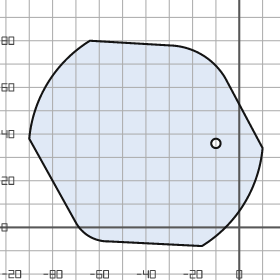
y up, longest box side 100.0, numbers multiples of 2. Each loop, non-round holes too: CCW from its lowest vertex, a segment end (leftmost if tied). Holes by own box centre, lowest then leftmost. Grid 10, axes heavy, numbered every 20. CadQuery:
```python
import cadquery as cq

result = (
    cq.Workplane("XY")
    .moveTo(-16.0, -8.0)
    .threePointArc((2.0, 10.0), (10.0, 34.0))
    .lineTo(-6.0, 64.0)
    .threePointArc((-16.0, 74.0), (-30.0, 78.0))
    .lineTo(-64.0, 80.0)
    .threePointArc((-82.0, 62.0), (-90.0, 38.0))
    .lineTo(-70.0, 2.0)
    .threePointArc((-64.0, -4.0), (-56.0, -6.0))
    .close()
    .moveTo(-10.0, 36.0)
    .circle(2.0)
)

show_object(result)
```